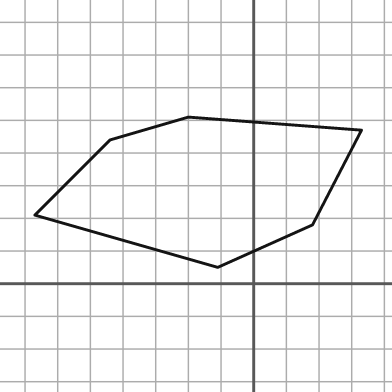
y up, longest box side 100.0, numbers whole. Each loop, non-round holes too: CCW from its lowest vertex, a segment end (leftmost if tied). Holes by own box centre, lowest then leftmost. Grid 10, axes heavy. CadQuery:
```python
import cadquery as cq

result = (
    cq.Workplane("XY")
    .moveTo(-11.0, 5.0)
    .lineTo(18.0, 18.0)
    .lineTo(33.0, 47.0)
    .lineTo(-20.0, 51.0)
    .lineTo(-44.0, 44.0)
    .lineTo(-67.0, 21.0)
    .close()
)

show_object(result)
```